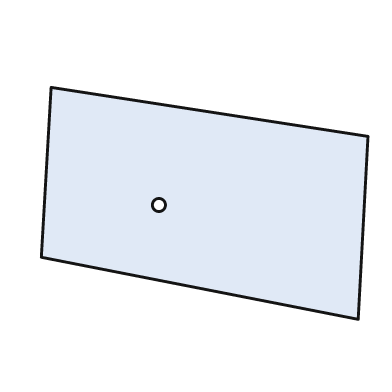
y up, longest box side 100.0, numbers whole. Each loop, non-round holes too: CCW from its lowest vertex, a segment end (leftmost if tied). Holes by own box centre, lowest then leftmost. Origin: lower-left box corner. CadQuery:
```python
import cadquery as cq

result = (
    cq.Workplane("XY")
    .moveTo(97.0, 0.0)
    .lineTo(100.0, 56.0)
    .lineTo(3.0, 71.0)
    .lineTo(0.0, 19.0)
    .close()
    .moveTo(36.0, 35.0)
    .circle(2.0)
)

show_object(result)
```